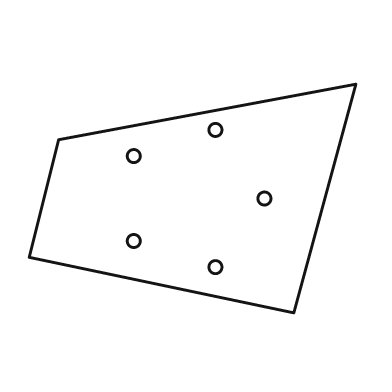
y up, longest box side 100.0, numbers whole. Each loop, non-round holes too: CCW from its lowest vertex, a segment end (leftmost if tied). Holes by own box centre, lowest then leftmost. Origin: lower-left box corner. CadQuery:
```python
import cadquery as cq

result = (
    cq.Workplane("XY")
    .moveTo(81.0, 0.0)
    .lineTo(100.0, 70.0)
    .lineTo(9.0, 53.0)
    .lineTo(0.0, 17.0)
    .close()
    .moveTo(57.0, 14.0)
    .circle(2.0)
    .moveTo(32.0, 22.0)
    .circle(2.0)
    .moveTo(72.0, 35.0)
    .circle(2.0)
    .moveTo(32.0, 48.0)
    .circle(2.0)
    .moveTo(57.0, 56.0)
    .circle(2.0)
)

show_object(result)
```